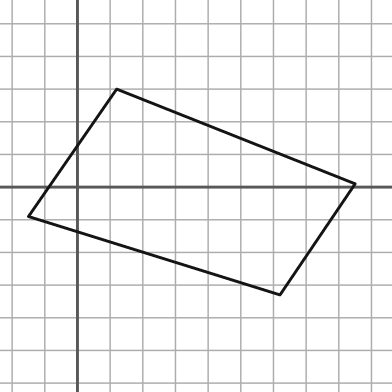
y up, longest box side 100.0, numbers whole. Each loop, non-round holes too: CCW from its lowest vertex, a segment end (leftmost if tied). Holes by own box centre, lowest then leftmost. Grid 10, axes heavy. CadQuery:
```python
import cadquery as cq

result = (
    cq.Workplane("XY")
    .moveTo(62.0, -33.0)
    .lineTo(85.0, 1.0)
    .lineTo(12.0, 30.0)
    .lineTo(-15.0, -9.0)
    .close()
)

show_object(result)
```